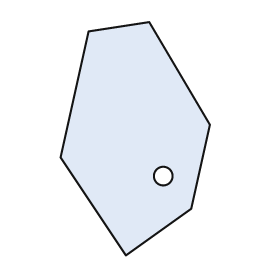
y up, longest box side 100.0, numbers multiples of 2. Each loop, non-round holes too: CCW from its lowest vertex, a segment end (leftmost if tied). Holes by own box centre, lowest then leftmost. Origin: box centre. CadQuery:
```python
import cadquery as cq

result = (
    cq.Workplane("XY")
    .moveTo(-4.0, -50.0)
    .lineTo(24.0, -30.0)
    .lineTo(32.0, 6.0)
    .lineTo(6.0, 50.0)
    .lineTo(-20.0, 46.0)
    .lineTo(-32.0, -8.0)
    .close()
    .moveTo(12.0, -16.0)
    .circle(4.0)
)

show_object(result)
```